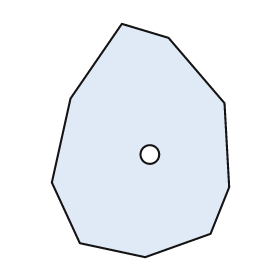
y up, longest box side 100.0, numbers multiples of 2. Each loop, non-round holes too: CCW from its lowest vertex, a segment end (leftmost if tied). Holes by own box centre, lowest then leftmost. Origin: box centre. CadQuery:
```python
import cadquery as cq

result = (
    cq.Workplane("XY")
    .moveTo(2.0, -50.0)
    .lineTo(30.0, -40.0)
    .lineTo(38.0, -20.0)
    .lineTo(36.0, 16.0)
    .lineTo(12.0, 44.0)
    .lineTo(-8.0, 50.0)
    .lineTo(-30.0, 18.0)
    .lineTo(-38.0, -18.0)
    .lineTo(-26.0, -44.0)
    .close()
    .moveTo(4.0, -6.0)
    .circle(4.0)
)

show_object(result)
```